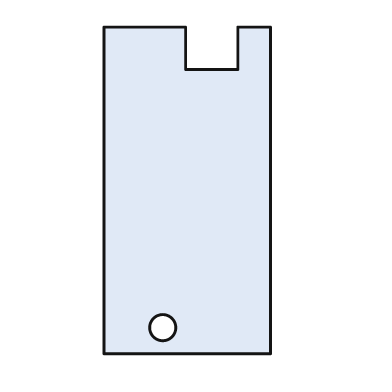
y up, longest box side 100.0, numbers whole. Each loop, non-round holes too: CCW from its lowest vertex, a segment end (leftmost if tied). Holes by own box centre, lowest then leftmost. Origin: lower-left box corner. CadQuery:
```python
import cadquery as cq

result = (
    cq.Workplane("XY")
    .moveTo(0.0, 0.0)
    .lineTo(51.0, 0.0)
    .lineTo(51.0, 100.0)
    .lineTo(41.0, 100.0)
    .lineTo(41.0, 87.0)
    .lineTo(25.0, 87.0)
    .lineTo(25.0, 100.0)
    .lineTo(0.0, 100.0)
    .close()
    .moveTo(18.0, 8.0)
    .circle(4.0)
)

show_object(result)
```